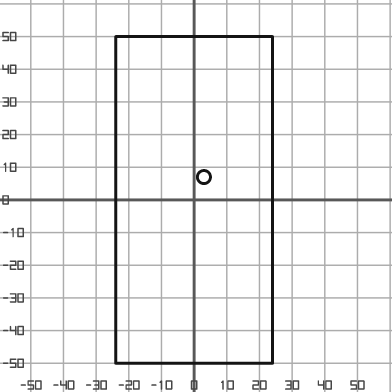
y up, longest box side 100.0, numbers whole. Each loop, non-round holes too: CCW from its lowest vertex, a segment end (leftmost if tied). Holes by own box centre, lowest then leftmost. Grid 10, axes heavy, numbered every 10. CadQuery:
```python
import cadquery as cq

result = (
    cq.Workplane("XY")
    .moveTo(-24.0, -50.0)
    .lineTo(24.0, -50.0)
    .lineTo(24.0, 50.0)
    .lineTo(-24.0, 50.0)
    .close()
    .moveTo(3.0, 7.0)
    .circle(2.0)
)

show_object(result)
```